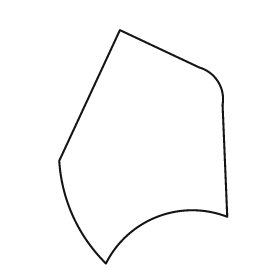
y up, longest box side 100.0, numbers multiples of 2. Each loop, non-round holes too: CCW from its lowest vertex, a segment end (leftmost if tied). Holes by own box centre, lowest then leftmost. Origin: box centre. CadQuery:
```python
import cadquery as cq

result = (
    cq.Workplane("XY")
    .moveTo(-16.0, -50.0)
    .threePointArc((6.0, -30.0), (36.0, -30.0))
    .lineTo(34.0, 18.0)
    .threePointArc((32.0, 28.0), (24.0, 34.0))
    .lineTo(-10.0, 50.0)
    .lineTo(-36.0, -6.0)
    .threePointArc((-30.0, -30.0), (-16.0, -50.0))
    .close()
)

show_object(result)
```